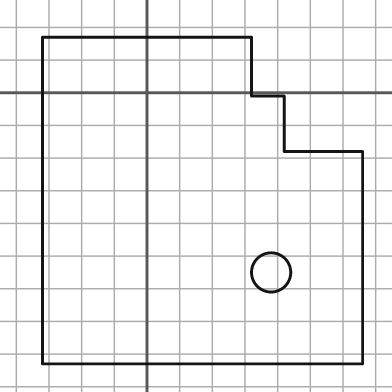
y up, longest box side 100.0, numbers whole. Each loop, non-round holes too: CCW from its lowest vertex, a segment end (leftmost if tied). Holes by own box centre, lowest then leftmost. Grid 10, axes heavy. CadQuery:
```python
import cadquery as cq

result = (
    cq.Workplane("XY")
    .moveTo(-32.0, -83.0)
    .lineTo(66.0, -83.0)
    .lineTo(66.0, -18.0)
    .lineTo(42.0, -18.0)
    .lineTo(42.0, -1.0)
    .lineTo(32.0, -1.0)
    .lineTo(32.0, 17.0)
    .lineTo(-32.0, 17.0)
    .close()
    .moveTo(38.0, -55.0)
    .circle(6.0)
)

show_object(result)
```